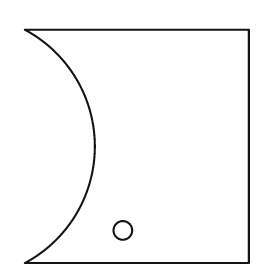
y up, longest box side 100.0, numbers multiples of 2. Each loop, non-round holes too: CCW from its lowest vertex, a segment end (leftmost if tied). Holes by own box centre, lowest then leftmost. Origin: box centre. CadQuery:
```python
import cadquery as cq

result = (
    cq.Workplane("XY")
    .moveTo(-48.0, -50.0)
    .lineTo(48.0, -50.0)
    .lineTo(48.0, 50.0)
    .lineTo(-48.0, 50.0)
    .threePointArc((-18.0, 0.0), (-48.0, -50.0))
    .close()
    .moveTo(-6.0, -36.0)
    .circle(4.0)
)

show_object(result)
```